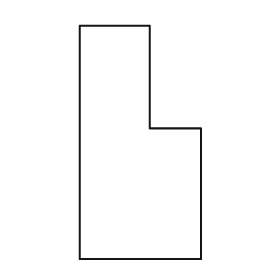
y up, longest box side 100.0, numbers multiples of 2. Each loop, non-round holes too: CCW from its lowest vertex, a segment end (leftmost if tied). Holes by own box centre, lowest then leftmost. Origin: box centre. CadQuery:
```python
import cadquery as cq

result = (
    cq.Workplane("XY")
    .moveTo(-26.0, -50.0)
    .lineTo(26.0, -50.0)
    .lineTo(26.0, 6.0)
    .lineTo(4.0, 6.0)
    .lineTo(4.0, 50.0)
    .lineTo(-26.0, 50.0)
    .close()
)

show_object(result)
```